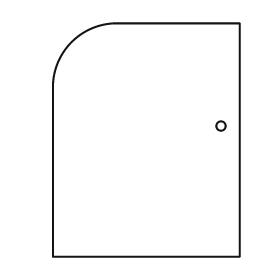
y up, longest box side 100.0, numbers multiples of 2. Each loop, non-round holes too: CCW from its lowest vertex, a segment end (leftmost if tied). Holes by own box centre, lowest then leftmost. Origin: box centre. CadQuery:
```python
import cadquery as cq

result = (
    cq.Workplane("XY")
    .moveTo(-40.0, -50.0)
    .lineTo(40.0, -50.0)
    .lineTo(40.0, 50.0)
    .lineTo(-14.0, 50.0)
    .threePointArc((-32.0, 42.0), (-40.0, 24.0))
    .close()
    .moveTo(32.0, 6.0)
    .circle(2.0)
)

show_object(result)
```